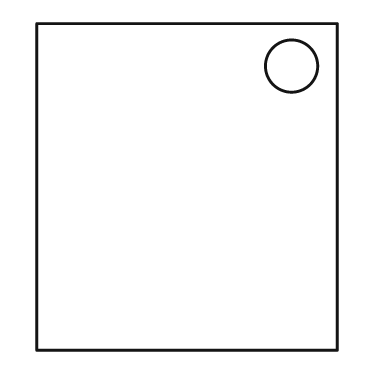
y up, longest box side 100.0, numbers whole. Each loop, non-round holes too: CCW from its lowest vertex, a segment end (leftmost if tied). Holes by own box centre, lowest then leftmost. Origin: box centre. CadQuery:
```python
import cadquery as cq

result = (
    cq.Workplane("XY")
    .moveTo(-46.0, -50.0)
    .lineTo(46.0, -50.0)
    .lineTo(46.0, 50.0)
    .lineTo(-46.0, 50.0)
    .close()
    .moveTo(32.0, 37.0)
    .circle(8.0)
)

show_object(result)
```